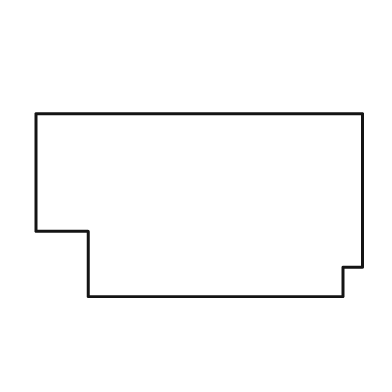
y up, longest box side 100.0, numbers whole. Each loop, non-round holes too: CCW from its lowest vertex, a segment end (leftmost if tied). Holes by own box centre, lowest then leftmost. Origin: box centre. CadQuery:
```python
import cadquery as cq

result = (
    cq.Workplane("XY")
    .moveTo(-34.0, -28.0)
    .lineTo(44.0, -28.0)
    .lineTo(44.0, -19.0)
    .lineTo(50.0, -19.0)
    .lineTo(50.0, 28.0)
    .lineTo(-50.0, 28.0)
    .lineTo(-50.0, -8.0)
    .lineTo(-34.0, -8.0)
    .close()
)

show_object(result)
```